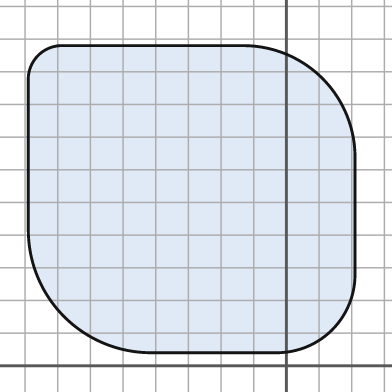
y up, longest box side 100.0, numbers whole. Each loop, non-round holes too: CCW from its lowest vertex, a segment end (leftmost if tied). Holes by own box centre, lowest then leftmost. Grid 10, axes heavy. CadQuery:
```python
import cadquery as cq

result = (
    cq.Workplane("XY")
    .moveTo(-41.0, 4.0)
    .lineTo(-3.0, 4.0)
    .threePointArc((14.0, 11.0), (21.0, 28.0))
    .lineTo(21.0, 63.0)
    .threePointArc((11.0, 88.0), (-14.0, 98.0))
    .lineTo(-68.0, 98.0)
    .threePointArc((-76.0, 95.0), (-79.0, 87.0))
    .lineTo(-79.0, 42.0)
    .threePointArc((-68.0, 15.0), (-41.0, 4.0))
    .close()
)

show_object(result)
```